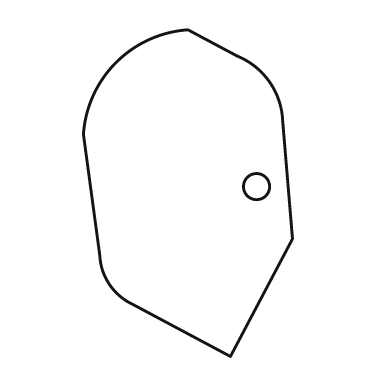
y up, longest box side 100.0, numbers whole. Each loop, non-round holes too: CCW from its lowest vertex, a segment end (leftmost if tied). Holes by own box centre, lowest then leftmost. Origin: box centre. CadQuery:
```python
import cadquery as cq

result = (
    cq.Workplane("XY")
    .moveTo(13.0, -50.0)
    .lineTo(32.0, -14.0)
    .lineTo(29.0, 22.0)
    .threePointArc((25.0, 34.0), (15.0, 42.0))
    .lineTo(0.0, 50.0)
    .threePointArc((-22.0, 40.0), (-32.0, 18.0))
    .lineTo(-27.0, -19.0)
    .threePointArc((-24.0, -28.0), (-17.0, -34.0))
    .close()
    .moveTo(21.0, 2.0)
    .circle(4.0)
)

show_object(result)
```